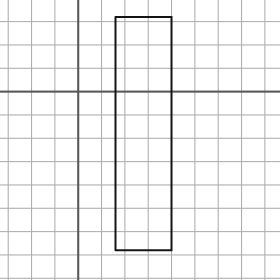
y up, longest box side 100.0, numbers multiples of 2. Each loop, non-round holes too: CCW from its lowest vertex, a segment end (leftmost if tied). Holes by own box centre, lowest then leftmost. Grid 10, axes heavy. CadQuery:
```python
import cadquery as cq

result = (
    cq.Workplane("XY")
    .moveTo(16.0, -68.0)
    .lineTo(40.0, -68.0)
    .lineTo(40.0, 32.0)
    .lineTo(16.0, 32.0)
    .close()
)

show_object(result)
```